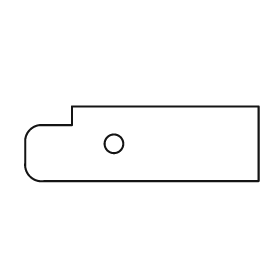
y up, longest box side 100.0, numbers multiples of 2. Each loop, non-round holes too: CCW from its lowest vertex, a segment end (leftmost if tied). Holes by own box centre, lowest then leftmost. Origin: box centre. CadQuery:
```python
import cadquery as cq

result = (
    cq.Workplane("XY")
    .moveTo(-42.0, -16.0)
    .lineTo(50.0, -16.0)
    .lineTo(50.0, 16.0)
    .lineTo(-30.0, 16.0)
    .lineTo(-30.0, 8.0)
    .lineTo(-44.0, 8.0)
    .threePointArc((-48.0, 6.0), (-50.0, 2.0))
    .lineTo(-50.0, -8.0)
    .threePointArc((-48.0, -14.0), (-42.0, -16.0))
    .close()
    .moveTo(-12.0, 0.0)
    .circle(4.0)
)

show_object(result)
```